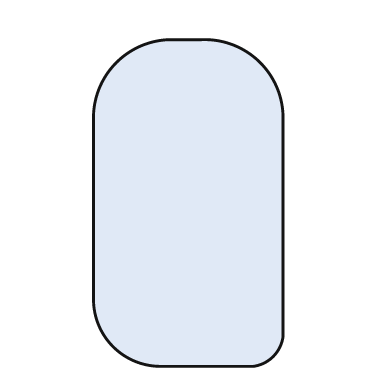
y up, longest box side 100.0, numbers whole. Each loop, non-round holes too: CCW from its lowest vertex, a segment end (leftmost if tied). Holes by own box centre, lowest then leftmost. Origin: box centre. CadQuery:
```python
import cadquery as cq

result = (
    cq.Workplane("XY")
    .moveTo(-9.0, -50.0)
    .lineTo(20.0, -50.0)
    .threePointArc((26.0, -47.0), (29.0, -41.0))
    .lineTo(29.0, 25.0)
    .threePointArc((22.0, 43.0), (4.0, 50.0))
    .lineTo(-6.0, 50.0)
    .threePointArc((-22.0, 43.0), (-29.0, 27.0))
    .lineTo(-29.0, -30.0)
    .threePointArc((-23.0, -44.0), (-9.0, -50.0))
    .close()
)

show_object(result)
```